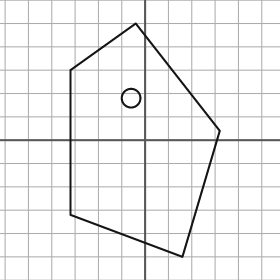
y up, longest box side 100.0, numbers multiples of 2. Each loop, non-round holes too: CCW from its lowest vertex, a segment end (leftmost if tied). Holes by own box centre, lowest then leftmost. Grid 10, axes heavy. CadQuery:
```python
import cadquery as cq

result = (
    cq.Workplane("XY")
    .moveTo(16.0, -50.0)
    .lineTo(32.0, 4.0)
    .lineTo(-4.0, 50.0)
    .lineTo(-32.0, 30.0)
    .lineTo(-32.0, -32.0)
    .close()
    .moveTo(-6.0, 18.0)
    .circle(4.0)
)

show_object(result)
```